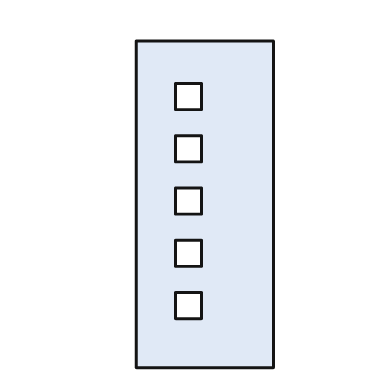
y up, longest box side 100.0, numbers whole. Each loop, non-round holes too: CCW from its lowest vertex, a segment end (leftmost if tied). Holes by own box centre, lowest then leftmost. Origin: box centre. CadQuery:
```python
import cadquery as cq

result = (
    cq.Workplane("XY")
    .moveTo(-21.0, -50.0)
    .lineTo(21.0, -50.0)
    .lineTo(21.0, 50.0)
    .lineTo(-21.0, 50.0)
    .close()
    .moveTo(-9.0, -35.0)
    .lineTo(-1.0, -35.0)
    .lineTo(-1.0, -27.0)
    .lineTo(-9.0, -27.0)
    .close()
    .moveTo(-9.0, -19.0)
    .lineTo(-1.0, -19.0)
    .lineTo(-1.0, -11.0)
    .lineTo(-9.0, -11.0)
    .close()
    .moveTo(-9.0, -3.0)
    .lineTo(-1.0, -3.0)
    .lineTo(-1.0, 5.0)
    .lineTo(-9.0, 5.0)
    .close()
    .moveTo(-9.0, 13.0)
    .lineTo(-1.0, 13.0)
    .lineTo(-1.0, 21.0)
    .lineTo(-9.0, 21.0)
    .close()
    .moveTo(-9.0, 29.0)
    .lineTo(-1.0, 29.0)
    .lineTo(-1.0, 37.0)
    .lineTo(-9.0, 37.0)
    .close()
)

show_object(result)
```